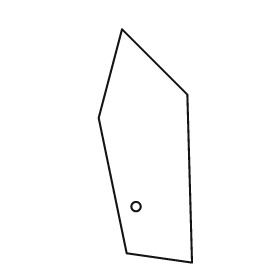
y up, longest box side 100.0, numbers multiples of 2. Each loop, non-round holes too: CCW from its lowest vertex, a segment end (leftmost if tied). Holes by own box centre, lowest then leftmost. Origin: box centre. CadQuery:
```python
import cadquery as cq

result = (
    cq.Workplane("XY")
    .moveTo(20.0, -50.0)
    .lineTo(18.0, 22.0)
    .lineTo(-10.0, 50.0)
    .lineTo(-20.0, 12.0)
    .lineTo(-8.0, -46.0)
    .close()
    .moveTo(-4.0, -26.0)
    .circle(2.0)
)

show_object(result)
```